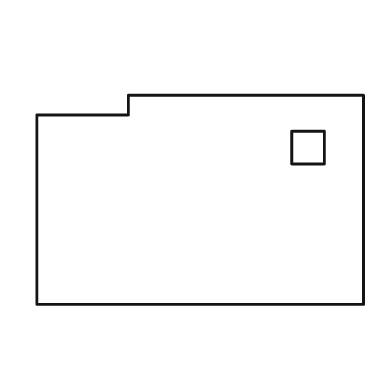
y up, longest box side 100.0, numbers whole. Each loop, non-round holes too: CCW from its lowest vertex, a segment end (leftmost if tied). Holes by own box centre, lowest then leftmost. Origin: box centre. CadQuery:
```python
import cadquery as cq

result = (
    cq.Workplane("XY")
    .moveTo(-50.0, -32.0)
    .lineTo(50.0, -32.0)
    .lineTo(50.0, 32.0)
    .lineTo(-22.0, 32.0)
    .lineTo(-22.0, 26.0)
    .lineTo(-50.0, 26.0)
    .close()
    .moveTo(28.0, 11.0)
    .lineTo(38.0, 11.0)
    .lineTo(38.0, 21.0)
    .lineTo(28.0, 21.0)
    .close()
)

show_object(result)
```